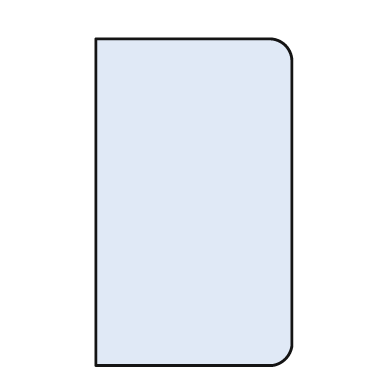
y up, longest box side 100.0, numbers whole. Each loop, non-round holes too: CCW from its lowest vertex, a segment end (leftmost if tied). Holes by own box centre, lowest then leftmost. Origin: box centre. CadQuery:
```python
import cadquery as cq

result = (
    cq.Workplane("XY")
    .moveTo(-30.0, -50.0)
    .lineTo(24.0, -50.0)
    .threePointArc((28.0, -48.0), (30.0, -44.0))
    .lineTo(30.0, 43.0)
    .threePointArc((28.0, 48.0), (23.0, 50.0))
    .lineTo(-30.0, 50.0)
    .close()
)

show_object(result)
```